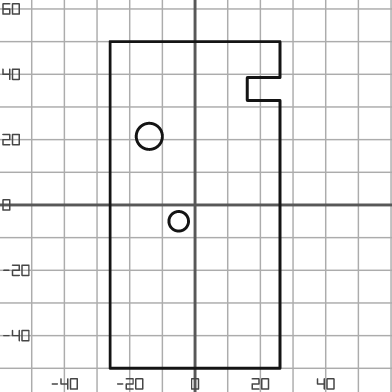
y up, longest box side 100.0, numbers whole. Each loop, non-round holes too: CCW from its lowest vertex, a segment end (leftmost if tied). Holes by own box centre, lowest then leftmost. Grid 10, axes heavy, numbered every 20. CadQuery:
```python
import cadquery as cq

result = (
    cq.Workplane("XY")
    .moveTo(-26.0, -50.0)
    .lineTo(26.0, -50.0)
    .lineTo(26.0, 32.0)
    .lineTo(16.0, 32.0)
    .lineTo(16.0, 39.0)
    .lineTo(26.0, 39.0)
    .lineTo(26.0, 50.0)
    .lineTo(-26.0, 50.0)
    .close()
    .moveTo(-5.0, -5.0)
    .circle(3.0)
    .moveTo(-14.0, 21.0)
    .circle(4.0)
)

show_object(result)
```